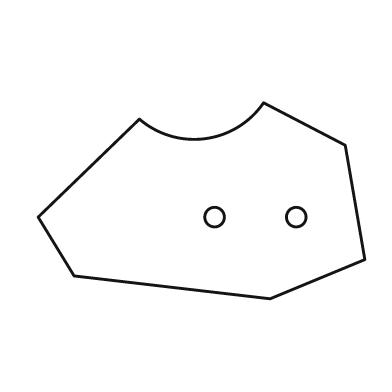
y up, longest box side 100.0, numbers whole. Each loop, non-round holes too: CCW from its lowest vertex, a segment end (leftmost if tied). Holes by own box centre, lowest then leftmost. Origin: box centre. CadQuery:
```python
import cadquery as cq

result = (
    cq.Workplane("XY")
    .moveTo(21.0, -30.0)
    .lineTo(50.0, -18.0)
    .lineTo(44.0, 17.0)
    .lineTo(19.0, 30.0)
    .threePointArc((1.0, 19.0), (-19.0, 25.0))
    .lineTo(-50.0, -5.0)
    .lineTo(-39.0, -23.0)
    .close()
    .moveTo(4.0, -5.0)
    .circle(3.0)
    .moveTo(29.0, -5.0)
    .circle(3.0)
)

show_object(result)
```